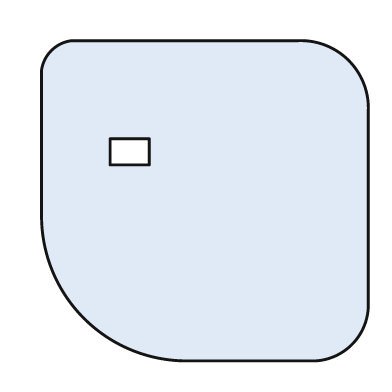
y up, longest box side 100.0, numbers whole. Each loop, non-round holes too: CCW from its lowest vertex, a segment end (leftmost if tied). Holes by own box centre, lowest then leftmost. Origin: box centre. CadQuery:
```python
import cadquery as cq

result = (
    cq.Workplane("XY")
    .moveTo(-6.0, -49.0)
    .lineTo(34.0, -49.0)
    .threePointArc((45.0, -44.0), (50.0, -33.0))
    .lineTo(50.0, 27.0)
    .threePointArc((44.0, 43.0), (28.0, 49.0))
    .lineTo(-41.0, 49.0)
    .threePointArc((-47.0, 46.0), (-50.0, 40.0))
    .lineTo(-50.0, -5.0)
    .threePointArc((-37.0, -36.0), (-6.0, -49.0))
    .close()
    .moveTo(-29.0, 11.0)
    .lineTo(-17.0, 11.0)
    .lineTo(-17.0, 19.0)
    .lineTo(-29.0, 19.0)
    .close()
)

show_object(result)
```